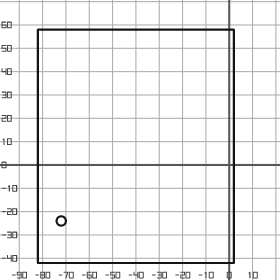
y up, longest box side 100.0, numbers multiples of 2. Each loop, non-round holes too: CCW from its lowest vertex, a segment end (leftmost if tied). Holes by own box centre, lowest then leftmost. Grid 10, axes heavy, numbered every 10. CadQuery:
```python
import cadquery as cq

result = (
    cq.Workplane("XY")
    .moveTo(-82.0, -42.0)
    .lineTo(2.0, -42.0)
    .lineTo(2.0, 58.0)
    .lineTo(-82.0, 58.0)
    .close()
    .moveTo(-72.0, -24.0)
    .circle(2.0)
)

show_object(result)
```